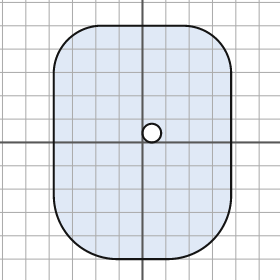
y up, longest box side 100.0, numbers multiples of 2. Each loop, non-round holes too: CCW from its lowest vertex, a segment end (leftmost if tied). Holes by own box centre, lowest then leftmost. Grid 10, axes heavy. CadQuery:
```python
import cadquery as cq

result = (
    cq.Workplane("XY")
    .moveTo(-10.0, -50.0)
    .lineTo(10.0, -50.0)
    .threePointArc((30.0, -42.0), (38.0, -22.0))
    .lineTo(38.0, 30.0)
    .threePointArc((32.0, 44.0), (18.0, 50.0))
    .lineTo(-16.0, 50.0)
    .threePointArc((-32.0, 44.0), (-38.0, 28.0))
    .lineTo(-38.0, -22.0)
    .threePointArc((-30.0, -42.0), (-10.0, -50.0))
    .close()
    .moveTo(4.0, 4.0)
    .circle(4.0)
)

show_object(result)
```